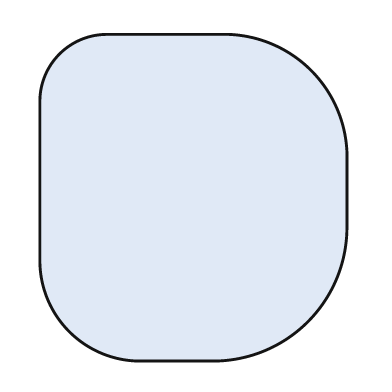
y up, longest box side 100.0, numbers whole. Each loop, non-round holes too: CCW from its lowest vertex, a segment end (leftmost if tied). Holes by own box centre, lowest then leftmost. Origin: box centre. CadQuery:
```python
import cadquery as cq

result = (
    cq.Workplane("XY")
    .moveTo(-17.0, -50.0)
    .lineTo(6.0, -50.0)
    .threePointArc((35.0, -38.0), (47.0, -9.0))
    .lineTo(47.0, 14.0)
    .threePointArc((36.0, 39.0), (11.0, 50.0))
    .lineTo(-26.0, 50.0)
    .threePointArc((-41.0, 44.0), (-47.0, 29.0))
    .lineTo(-47.0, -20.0)
    .threePointArc((-38.0, -41.0), (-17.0, -50.0))
    .close()
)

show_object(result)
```